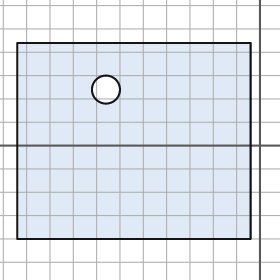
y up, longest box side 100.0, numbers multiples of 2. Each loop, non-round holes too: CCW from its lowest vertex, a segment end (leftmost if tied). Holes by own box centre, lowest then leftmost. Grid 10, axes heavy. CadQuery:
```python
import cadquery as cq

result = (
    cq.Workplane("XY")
    .moveTo(-104.0, -40.0)
    .lineTo(-4.0, -40.0)
    .lineTo(-4.0, 44.0)
    .lineTo(-104.0, 44.0)
    .close()
    .moveTo(-66.0, 24.0)
    .circle(6.0)
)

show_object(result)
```